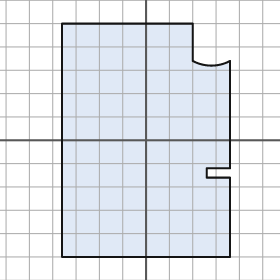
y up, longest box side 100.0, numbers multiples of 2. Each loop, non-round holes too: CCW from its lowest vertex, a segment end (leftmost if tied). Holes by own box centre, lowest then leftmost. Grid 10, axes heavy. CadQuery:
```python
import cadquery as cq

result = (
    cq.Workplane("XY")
    .moveTo(-36.0, -50.0)
    .lineTo(36.0, -50.0)
    .lineTo(36.0, -16.0)
    .lineTo(26.0, -16.0)
    .lineTo(26.0, -12.0)
    .lineTo(36.0, -12.0)
    .lineTo(36.0, 34.0)
    .threePointArc((28.0, 32.0), (20.0, 34.0))
    .lineTo(20.0, 50.0)
    .lineTo(-36.0, 50.0)
    .close()
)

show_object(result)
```